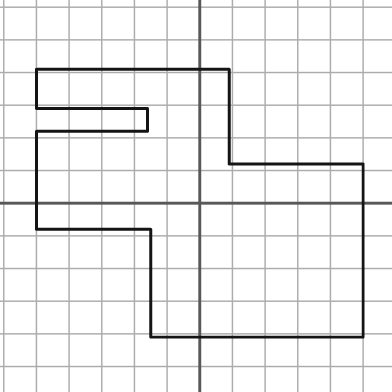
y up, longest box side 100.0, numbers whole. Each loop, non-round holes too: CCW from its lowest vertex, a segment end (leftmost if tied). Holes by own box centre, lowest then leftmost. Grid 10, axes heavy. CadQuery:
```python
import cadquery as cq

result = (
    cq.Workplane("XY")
    .moveTo(-15.0, -41.0)
    .lineTo(50.0, -41.0)
    .lineTo(50.0, 12.0)
    .lineTo(9.0, 12.0)
    .lineTo(9.0, 41.0)
    .lineTo(-50.0, 41.0)
    .lineTo(-50.0, 29.0)
    .lineTo(-16.0, 29.0)
    .lineTo(-16.0, 22.0)
    .lineTo(-50.0, 22.0)
    .lineTo(-50.0, -8.0)
    .lineTo(-15.0, -8.0)
    .close()
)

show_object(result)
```